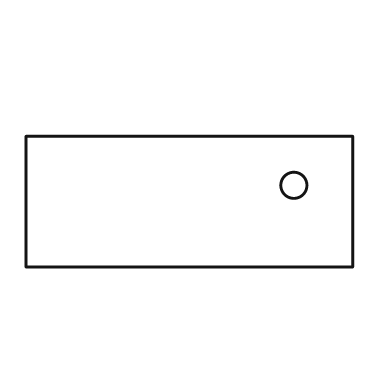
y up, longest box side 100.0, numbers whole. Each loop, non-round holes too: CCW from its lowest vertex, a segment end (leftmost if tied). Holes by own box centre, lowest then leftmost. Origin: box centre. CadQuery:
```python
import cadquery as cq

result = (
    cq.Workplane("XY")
    .moveTo(-50.0, -20.0)
    .lineTo(50.0, -20.0)
    .lineTo(50.0, 20.0)
    .lineTo(-50.0, 20.0)
    .close()
    .moveTo(32.0, 5.0)
    .circle(4.0)
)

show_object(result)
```